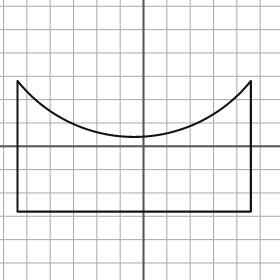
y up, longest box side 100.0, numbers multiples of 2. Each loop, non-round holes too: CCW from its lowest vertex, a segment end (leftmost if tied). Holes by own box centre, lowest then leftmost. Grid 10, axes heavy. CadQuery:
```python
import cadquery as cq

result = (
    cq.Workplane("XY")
    .moveTo(-54.0, -28.0)
    .lineTo(46.0, -28.0)
    .lineTo(46.0, 28.0)
    .threePointArc((-4.0, 4.0), (-54.0, 28.0))
    .close()
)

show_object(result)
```